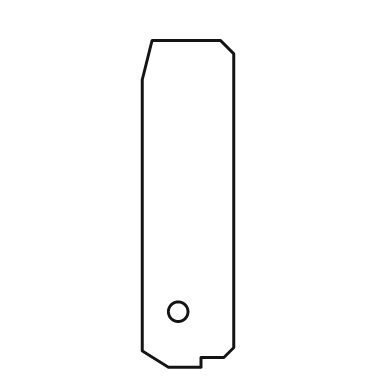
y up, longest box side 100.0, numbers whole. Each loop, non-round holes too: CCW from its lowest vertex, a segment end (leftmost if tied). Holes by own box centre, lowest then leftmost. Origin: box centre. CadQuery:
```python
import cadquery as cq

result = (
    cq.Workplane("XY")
    .moveTo(-6.0, -50.0)
    .lineTo(4.0, -50.0)
    .lineTo(4.0, -47.0)
    .lineTo(11.0, -47.0)
    .lineTo(14.0, -44.0)
    .lineTo(14.0, 46.0)
    .lineTo(10.0, 50.0)
    .lineTo(-11.0, 50.0)
    .lineTo(-14.0, 38.0)
    .lineTo(-14.0, -45.0)
    .close()
    .moveTo(-3.0, -33.0)
    .circle(3.0)
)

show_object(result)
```